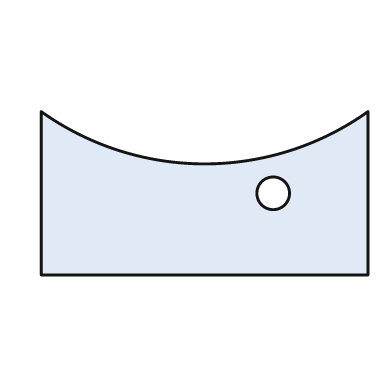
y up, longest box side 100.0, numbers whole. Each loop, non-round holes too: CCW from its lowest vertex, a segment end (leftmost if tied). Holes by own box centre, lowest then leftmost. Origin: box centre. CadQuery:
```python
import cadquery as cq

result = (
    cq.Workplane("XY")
    .moveTo(-50.0, -25.0)
    .lineTo(50.0, -25.0)
    .lineTo(50.0, 25.0)
    .threePointArc((0.0, 9.0), (-50.0, 25.0))
    .close()
    .moveTo(21.0, 0.0)
    .circle(5.0)
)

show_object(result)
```